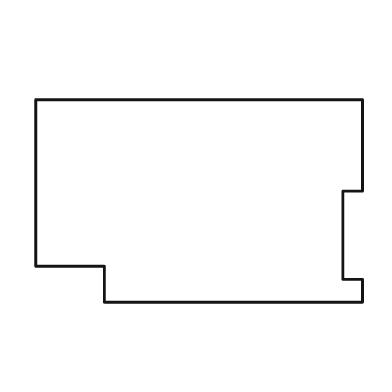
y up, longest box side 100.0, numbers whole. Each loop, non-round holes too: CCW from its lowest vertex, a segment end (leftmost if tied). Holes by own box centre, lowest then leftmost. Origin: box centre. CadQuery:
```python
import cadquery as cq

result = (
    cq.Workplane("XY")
    .moveTo(-29.0, -31.0)
    .lineTo(50.0, -31.0)
    .lineTo(50.0, -24.0)
    .lineTo(44.0, -24.0)
    .lineTo(44.0, 3.0)
    .lineTo(50.0, 3.0)
    .lineTo(50.0, 31.0)
    .lineTo(-50.0, 31.0)
    .lineTo(-50.0, -20.0)
    .lineTo(-29.0, -20.0)
    .close()
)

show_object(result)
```